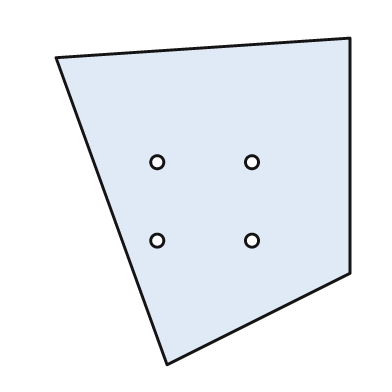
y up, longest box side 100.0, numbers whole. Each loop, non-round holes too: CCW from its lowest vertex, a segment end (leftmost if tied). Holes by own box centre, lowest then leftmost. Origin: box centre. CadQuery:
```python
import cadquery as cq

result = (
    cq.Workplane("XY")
    .moveTo(-11.0, -50.0)
    .lineTo(45.0, -22.0)
    .lineTo(45.0, 50.0)
    .lineTo(-45.0, 44.0)
    .close()
    .moveTo(-14.0, -12.0)
    .circle(2.0)
    .moveTo(15.0, -12.0)
    .circle(2.0)
    .moveTo(-14.0, 12.0)
    .circle(2.0)
    .moveTo(15.0, 12.0)
    .circle(2.0)
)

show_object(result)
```